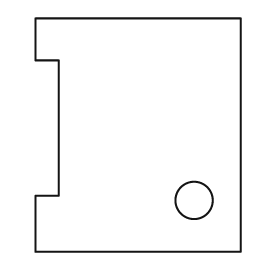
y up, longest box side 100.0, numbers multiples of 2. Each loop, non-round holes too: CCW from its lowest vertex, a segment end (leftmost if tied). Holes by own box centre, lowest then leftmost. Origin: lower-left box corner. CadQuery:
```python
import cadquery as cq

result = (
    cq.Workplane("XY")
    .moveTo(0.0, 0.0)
    .lineTo(88.0, 0.0)
    .lineTo(88.0, 100.0)
    .lineTo(0.0, 100.0)
    .lineTo(0.0, 82.0)
    .lineTo(10.0, 82.0)
    .lineTo(10.0, 24.0)
    .lineTo(0.0, 24.0)
    .close()
    .moveTo(68.0, 22.0)
    .circle(8.0)
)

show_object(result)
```